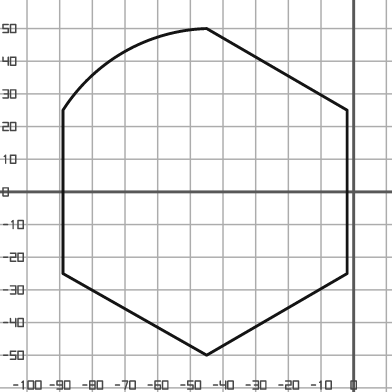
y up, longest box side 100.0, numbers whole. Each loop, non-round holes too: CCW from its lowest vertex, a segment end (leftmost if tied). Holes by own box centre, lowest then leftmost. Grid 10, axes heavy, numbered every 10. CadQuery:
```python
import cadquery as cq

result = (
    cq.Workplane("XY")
    .moveTo(-45.0, -50.0)
    .lineTo(-2.0, -25.0)
    .lineTo(-2.0, 25.0)
    .lineTo(-45.0, 50.0)
    .threePointArc((-70.0, 43.0), (-89.0, 25.0))
    .lineTo(-89.0, -25.0)
    .close()
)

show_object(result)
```